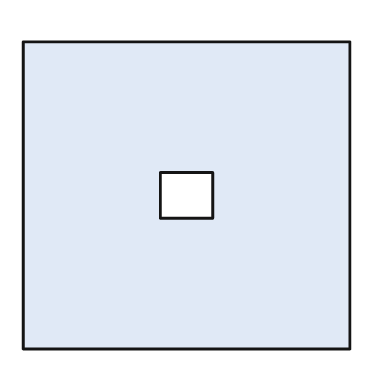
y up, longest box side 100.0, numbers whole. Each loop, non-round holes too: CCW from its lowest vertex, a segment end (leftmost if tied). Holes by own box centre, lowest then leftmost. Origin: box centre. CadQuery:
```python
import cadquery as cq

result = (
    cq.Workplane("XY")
    .moveTo(-50.0, -47.0)
    .lineTo(50.0, -47.0)
    .lineTo(50.0, 47.0)
    .lineTo(-50.0, 47.0)
    .close()
    .moveTo(-8.0, -7.0)
    .lineTo(8.0, -7.0)
    .lineTo(8.0, 7.0)
    .lineTo(-8.0, 7.0)
    .close()
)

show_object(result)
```